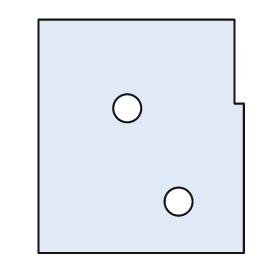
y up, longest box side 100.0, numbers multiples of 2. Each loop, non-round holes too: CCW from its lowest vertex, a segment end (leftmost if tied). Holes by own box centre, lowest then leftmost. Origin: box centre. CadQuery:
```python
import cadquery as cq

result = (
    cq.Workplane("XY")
    .moveTo(-44.0, -50.0)
    .lineTo(44.0, -50.0)
    .lineTo(44.0, 14.0)
    .lineTo(40.0, 14.0)
    .lineTo(40.0, 50.0)
    .lineTo(-44.0, 50.0)
    .close()
    .moveTo(16.0, -28.0)
    .circle(6.0)
    .moveTo(-6.0, 12.0)
    .circle(6.0)
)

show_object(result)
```